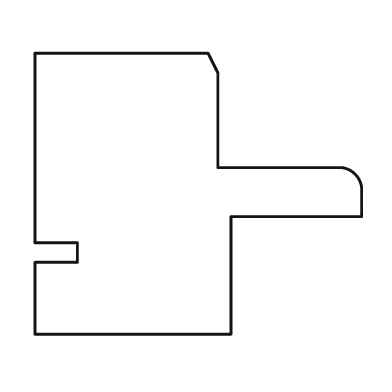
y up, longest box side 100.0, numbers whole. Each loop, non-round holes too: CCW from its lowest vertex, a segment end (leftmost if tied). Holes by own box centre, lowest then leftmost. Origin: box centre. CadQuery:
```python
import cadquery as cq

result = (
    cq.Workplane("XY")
    .moveTo(-50.0, -43.0)
    .lineTo(10.0, -43.0)
    .lineTo(10.0, -7.0)
    .lineTo(50.0, -7.0)
    .lineTo(50.0, 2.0)
    .threePointArc((48.0, 6.0), (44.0, 8.0))
    .lineTo(6.0, 8.0)
    .lineTo(6.0, 37.0)
    .lineTo(3.0, 43.0)
    .lineTo(-50.0, 43.0)
    .lineTo(-50.0, -15.0)
    .lineTo(-37.0, -15.0)
    .lineTo(-37.0, -21.0)
    .lineTo(-50.0, -21.0)
    .close()
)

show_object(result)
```